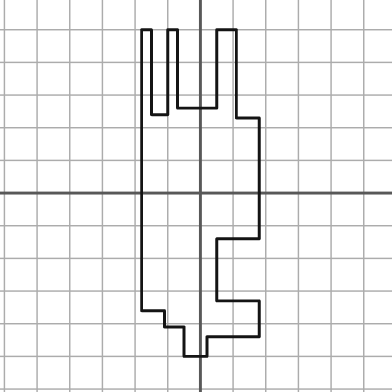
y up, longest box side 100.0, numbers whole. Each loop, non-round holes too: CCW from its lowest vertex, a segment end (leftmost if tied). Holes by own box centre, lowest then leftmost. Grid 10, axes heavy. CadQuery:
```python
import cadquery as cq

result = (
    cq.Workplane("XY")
    .moveTo(-5.0, -50.0)
    .lineTo(2.0, -50.0)
    .lineTo(2.0, -44.0)
    .lineTo(18.0, -44.0)
    .lineTo(18.0, -33.0)
    .lineTo(5.0, -33.0)
    .lineTo(5.0, -14.0)
    .lineTo(18.0, -14.0)
    .lineTo(18.0, 23.0)
    .lineTo(11.0, 23.0)
    .lineTo(11.0, 50.0)
    .lineTo(5.0, 50.0)
    .lineTo(5.0, 26.0)
    .lineTo(-7.0, 26.0)
    .lineTo(-7.0, 50.0)
    .lineTo(-10.0, 50.0)
    .lineTo(-10.0, 24.0)
    .lineTo(-15.0, 24.0)
    .lineTo(-15.0, 50.0)
    .lineTo(-18.0, 50.0)
    .lineTo(-18.0, -36.0)
    .lineTo(-11.0, -36.0)
    .lineTo(-11.0, -41.0)
    .lineTo(-5.0, -41.0)
    .close()
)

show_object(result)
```